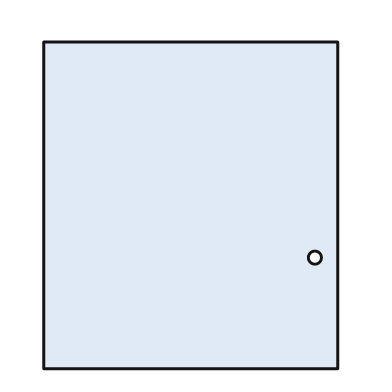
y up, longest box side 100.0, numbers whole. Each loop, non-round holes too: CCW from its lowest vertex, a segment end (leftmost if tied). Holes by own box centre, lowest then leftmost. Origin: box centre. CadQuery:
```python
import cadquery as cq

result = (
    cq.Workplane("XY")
    .moveTo(-45.0, -50.0)
    .lineTo(45.0, -50.0)
    .lineTo(45.0, 50.0)
    .lineTo(-45.0, 50.0)
    .close()
    .moveTo(38.0, -16.0)
    .circle(2.0)
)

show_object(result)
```